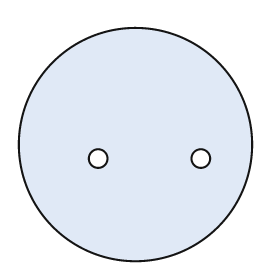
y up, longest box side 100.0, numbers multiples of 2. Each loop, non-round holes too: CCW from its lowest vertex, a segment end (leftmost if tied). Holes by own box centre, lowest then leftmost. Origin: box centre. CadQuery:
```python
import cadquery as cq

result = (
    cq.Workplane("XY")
    .moveTo(0.0, 0.0)
    .circle(50.0)
    .moveTo(-16.0, -6.0)
    .circle(4.0)
    .moveTo(28.0, -6.0)
    .circle(4.0)
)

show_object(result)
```